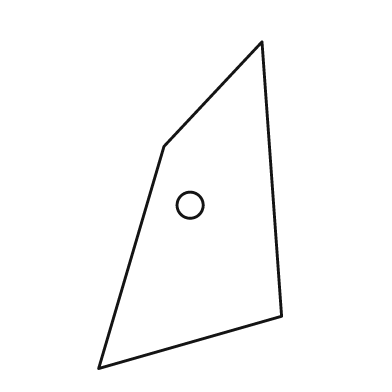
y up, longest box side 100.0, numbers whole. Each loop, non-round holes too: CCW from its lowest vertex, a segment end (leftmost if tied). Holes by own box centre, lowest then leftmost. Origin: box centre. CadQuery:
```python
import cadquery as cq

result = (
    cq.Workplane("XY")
    .moveTo(-28.0, -50.0)
    .lineTo(28.0, -34.0)
    .lineTo(22.0, 50.0)
    .lineTo(-8.0, 18.0)
    .close()
    .moveTo(0.0, 0.0)
    .circle(4.0)
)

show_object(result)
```